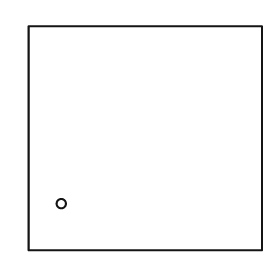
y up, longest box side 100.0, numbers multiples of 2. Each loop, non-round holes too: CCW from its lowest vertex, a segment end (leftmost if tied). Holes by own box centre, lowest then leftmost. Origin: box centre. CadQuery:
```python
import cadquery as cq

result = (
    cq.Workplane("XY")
    .moveTo(-50.0, -48.0)
    .lineTo(50.0, -48.0)
    .lineTo(50.0, 48.0)
    .lineTo(-50.0, 48.0)
    .close()
    .moveTo(-36.0, -28.0)
    .circle(2.0)
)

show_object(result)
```